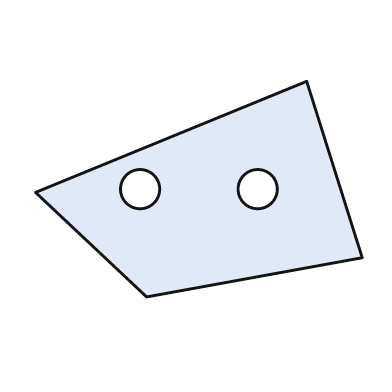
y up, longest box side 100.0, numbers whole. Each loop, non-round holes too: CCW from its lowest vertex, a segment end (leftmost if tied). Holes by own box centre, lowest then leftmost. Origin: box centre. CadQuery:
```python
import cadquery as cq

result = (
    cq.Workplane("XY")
    .moveTo(-16.0, -33.0)
    .lineTo(50.0, -21.0)
    .lineTo(33.0, 33.0)
    .lineTo(-50.0, -1.0)
    .close()
    .moveTo(-18.0, 0.0)
    .circle(6.0)
    .moveTo(18.0, 0.0)
    .circle(6.0)
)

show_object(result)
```